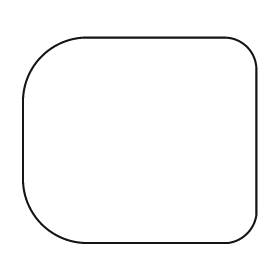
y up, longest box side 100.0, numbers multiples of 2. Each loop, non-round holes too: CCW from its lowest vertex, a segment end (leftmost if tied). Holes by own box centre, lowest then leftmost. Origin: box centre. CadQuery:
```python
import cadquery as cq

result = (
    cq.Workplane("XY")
    .moveTo(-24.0, -44.0)
    .lineTo(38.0, -44.0)
    .threePointArc((46.0, -40.0), (50.0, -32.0))
    .lineTo(50.0, 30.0)
    .threePointArc((46.0, 40.0), (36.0, 44.0))
    .lineTo(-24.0, 44.0)
    .threePointArc((-42.0, 36.0), (-50.0, 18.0))
    .lineTo(-50.0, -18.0)
    .threePointArc((-42.0, -36.0), (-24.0, -44.0))
    .close()
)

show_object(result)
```